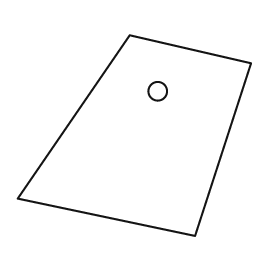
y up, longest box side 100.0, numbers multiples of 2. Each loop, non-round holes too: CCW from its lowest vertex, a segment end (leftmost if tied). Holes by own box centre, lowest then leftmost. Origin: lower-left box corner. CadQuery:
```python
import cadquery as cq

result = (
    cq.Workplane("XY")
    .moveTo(76.0, 0.0)
    .lineTo(100.0, 74.0)
    .lineTo(48.0, 86.0)
    .lineTo(0.0, 16.0)
    .close()
    .moveTo(60.0, 62.0)
    .circle(4.0)
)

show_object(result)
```